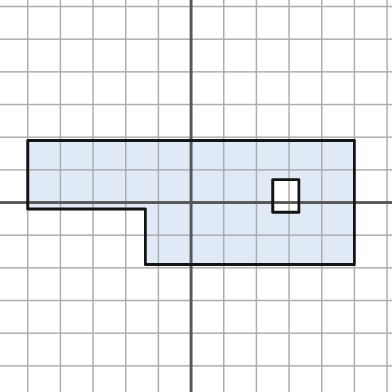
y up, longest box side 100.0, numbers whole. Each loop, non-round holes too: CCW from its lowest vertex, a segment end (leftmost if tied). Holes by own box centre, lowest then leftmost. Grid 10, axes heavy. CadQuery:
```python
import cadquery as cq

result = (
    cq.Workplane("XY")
    .moveTo(-14.0, -19.0)
    .lineTo(50.0, -19.0)
    .lineTo(50.0, 19.0)
    .lineTo(-50.0, 19.0)
    .lineTo(-50.0, -2.0)
    .lineTo(-14.0, -2.0)
    .close()
    .moveTo(25.0, -3.0)
    .lineTo(33.0, -3.0)
    .lineTo(33.0, 7.0)
    .lineTo(25.0, 7.0)
    .close()
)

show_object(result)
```